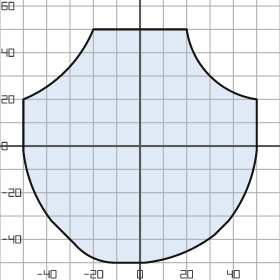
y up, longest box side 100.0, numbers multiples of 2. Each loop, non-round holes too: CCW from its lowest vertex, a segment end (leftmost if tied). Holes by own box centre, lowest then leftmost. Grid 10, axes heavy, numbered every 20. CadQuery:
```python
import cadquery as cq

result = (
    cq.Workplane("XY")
    .moveTo(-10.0, -50.0)
    .lineTo(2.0, -50.0)
    .threePointArc((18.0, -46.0), (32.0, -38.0))
    .lineTo(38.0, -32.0)
    .threePointArc((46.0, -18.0), (50.0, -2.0))
    .lineTo(50.0, 20.0)
    .threePointArc((30.0, 30.0), (20.0, 50.0))
    .lineTo(-20.0, 50.0)
    .threePointArc((-32.0, 32.0), (-50.0, 20.0))
    .lineTo(-50.0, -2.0)
    .threePointArc((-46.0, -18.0), (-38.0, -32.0))
    .lineTo(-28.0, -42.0)
    .threePointArc((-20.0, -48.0), (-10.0, -50.0))
    .close()
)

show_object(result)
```